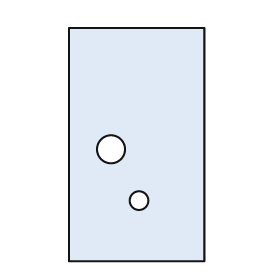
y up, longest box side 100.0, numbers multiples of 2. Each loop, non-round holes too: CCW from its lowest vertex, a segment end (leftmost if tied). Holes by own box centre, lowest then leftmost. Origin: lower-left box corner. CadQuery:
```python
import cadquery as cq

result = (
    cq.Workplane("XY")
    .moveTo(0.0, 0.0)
    .lineTo(58.0, 0.0)
    .lineTo(58.0, 100.0)
    .lineTo(0.0, 100.0)
    .close()
    .moveTo(30.0, 26.0)
    .circle(4.0)
    .moveTo(18.0, 48.0)
    .circle(6.0)
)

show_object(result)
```